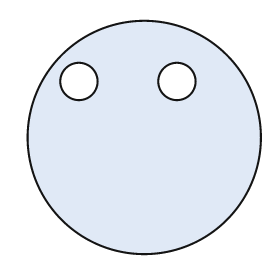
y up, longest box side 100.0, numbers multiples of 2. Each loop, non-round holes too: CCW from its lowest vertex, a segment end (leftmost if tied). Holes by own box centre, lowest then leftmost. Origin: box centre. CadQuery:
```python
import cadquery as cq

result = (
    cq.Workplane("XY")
    .moveTo(0.0, 0.0)
    .circle(50.0)
    .moveTo(-28.0, 24.0)
    .circle(8.0)
    .moveTo(14.0, 24.0)
    .circle(8.0)
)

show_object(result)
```